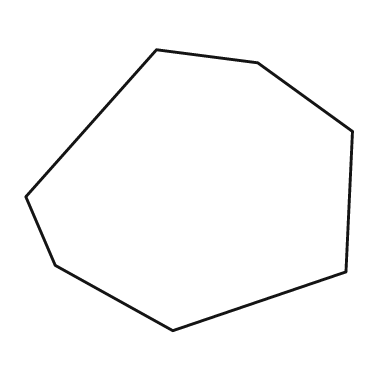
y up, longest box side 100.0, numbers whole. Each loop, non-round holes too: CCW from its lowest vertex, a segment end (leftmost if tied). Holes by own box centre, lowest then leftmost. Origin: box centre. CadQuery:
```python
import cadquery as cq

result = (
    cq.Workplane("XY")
    .moveTo(-5.0, -43.0)
    .lineTo(48.0, -25.0)
    .lineTo(50.0, 18.0)
    .lineTo(21.0, 39.0)
    .lineTo(-10.0, 43.0)
    .lineTo(-50.0, -2.0)
    .lineTo(-41.0, -23.0)
    .close()
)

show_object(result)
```